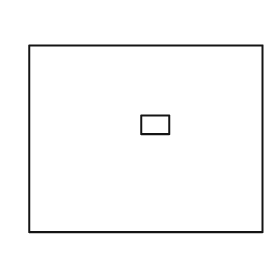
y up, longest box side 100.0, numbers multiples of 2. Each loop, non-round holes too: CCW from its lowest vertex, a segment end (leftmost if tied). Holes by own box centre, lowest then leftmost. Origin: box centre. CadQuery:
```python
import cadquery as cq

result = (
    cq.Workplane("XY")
    .moveTo(-50.0, -40.0)
    .lineTo(50.0, -40.0)
    .lineTo(50.0, 40.0)
    .lineTo(-50.0, 40.0)
    .close()
    .moveTo(-2.0, 2.0)
    .lineTo(10.0, 2.0)
    .lineTo(10.0, 10.0)
    .lineTo(-2.0, 10.0)
    .close()
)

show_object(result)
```